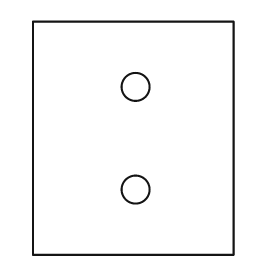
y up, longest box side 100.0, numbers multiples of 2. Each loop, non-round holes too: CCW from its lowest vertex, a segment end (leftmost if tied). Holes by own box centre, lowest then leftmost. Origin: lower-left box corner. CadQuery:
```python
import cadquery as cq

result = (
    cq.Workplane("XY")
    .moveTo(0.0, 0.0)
    .lineTo(86.0, 0.0)
    .lineTo(86.0, 100.0)
    .lineTo(0.0, 100.0)
    .close()
    .moveTo(44.0, 28.0)
    .circle(6.0)
    .moveTo(44.0, 72.0)
    .circle(6.0)
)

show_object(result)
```